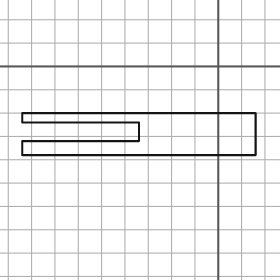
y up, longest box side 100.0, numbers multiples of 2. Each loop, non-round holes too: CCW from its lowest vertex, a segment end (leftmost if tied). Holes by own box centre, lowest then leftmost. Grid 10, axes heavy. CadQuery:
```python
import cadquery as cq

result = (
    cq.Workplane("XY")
    .moveTo(-84.0, -38.0)
    .lineTo(16.0, -38.0)
    .lineTo(16.0, -20.0)
    .lineTo(-84.0, -20.0)
    .lineTo(-84.0, -24.0)
    .lineTo(-34.0, -24.0)
    .lineTo(-34.0, -32.0)
    .lineTo(-84.0, -32.0)
    .close()
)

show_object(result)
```